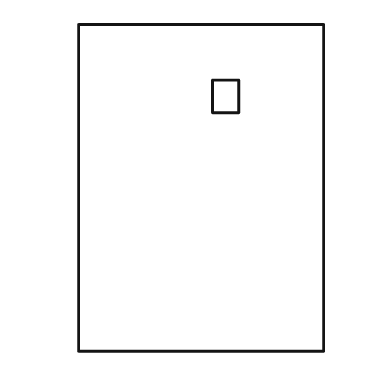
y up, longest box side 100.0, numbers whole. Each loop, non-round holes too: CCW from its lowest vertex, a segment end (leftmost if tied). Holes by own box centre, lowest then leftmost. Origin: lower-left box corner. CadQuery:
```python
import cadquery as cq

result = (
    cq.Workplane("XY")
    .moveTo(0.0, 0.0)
    .lineTo(75.0, 0.0)
    .lineTo(75.0, 100.0)
    .lineTo(0.0, 100.0)
    .close()
    .moveTo(41.0, 73.0)
    .lineTo(49.0, 73.0)
    .lineTo(49.0, 83.0)
    .lineTo(41.0, 83.0)
    .close()
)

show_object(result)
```